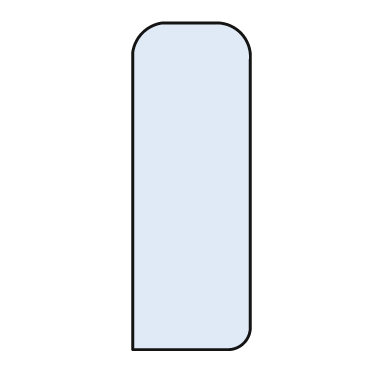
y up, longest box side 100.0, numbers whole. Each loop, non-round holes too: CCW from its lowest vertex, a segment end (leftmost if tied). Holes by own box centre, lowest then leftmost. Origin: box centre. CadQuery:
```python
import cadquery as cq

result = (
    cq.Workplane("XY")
    .moveTo(-18.0, -50.0)
    .lineTo(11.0, -50.0)
    .threePointArc((16.0, -48.0), (18.0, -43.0))
    .lineTo(18.0, 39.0)
    .threePointArc((15.0, 47.0), (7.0, 50.0))
    .lineTo(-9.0, 50.0)
    .threePointArc((-15.0, 47.0), (-18.0, 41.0))
    .close()
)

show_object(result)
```